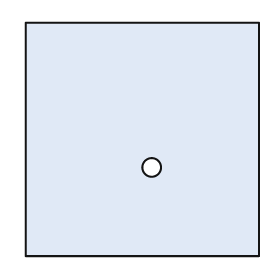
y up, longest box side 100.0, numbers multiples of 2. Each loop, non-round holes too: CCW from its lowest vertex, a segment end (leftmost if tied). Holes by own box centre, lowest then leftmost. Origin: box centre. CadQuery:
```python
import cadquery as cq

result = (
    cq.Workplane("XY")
    .moveTo(-50.0, -50.0)
    .lineTo(50.0, -50.0)
    .lineTo(50.0, 50.0)
    .lineTo(-50.0, 50.0)
    .close()
    .moveTo(4.0, -12.0)
    .circle(4.0)
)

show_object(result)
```